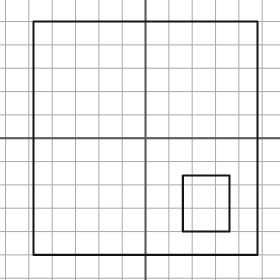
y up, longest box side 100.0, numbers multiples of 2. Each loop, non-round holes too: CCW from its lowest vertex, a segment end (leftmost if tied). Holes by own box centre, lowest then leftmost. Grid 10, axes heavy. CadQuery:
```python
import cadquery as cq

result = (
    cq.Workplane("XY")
    .moveTo(-48.0, -50.0)
    .lineTo(48.0, -50.0)
    .lineTo(48.0, 50.0)
    .lineTo(-48.0, 50.0)
    .close()
    .moveTo(16.0, -40.0)
    .lineTo(36.0, -40.0)
    .lineTo(36.0, -16.0)
    .lineTo(16.0, -16.0)
    .close()
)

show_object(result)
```